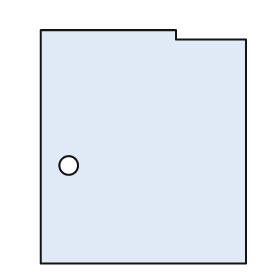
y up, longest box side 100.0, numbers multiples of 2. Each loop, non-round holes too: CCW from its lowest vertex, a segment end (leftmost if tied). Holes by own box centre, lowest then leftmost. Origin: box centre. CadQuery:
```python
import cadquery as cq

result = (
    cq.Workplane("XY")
    .moveTo(-44.0, -50.0)
    .lineTo(44.0, -50.0)
    .lineTo(44.0, 46.0)
    .lineTo(14.0, 46.0)
    .lineTo(14.0, 50.0)
    .lineTo(-44.0, 50.0)
    .close()
    .moveTo(-32.0, -8.0)
    .circle(4.0)
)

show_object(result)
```